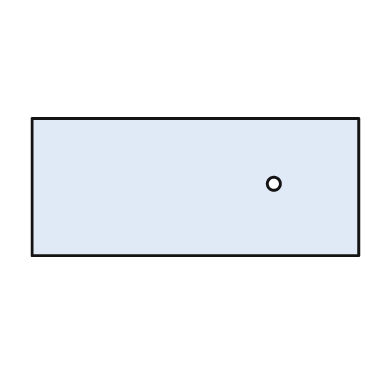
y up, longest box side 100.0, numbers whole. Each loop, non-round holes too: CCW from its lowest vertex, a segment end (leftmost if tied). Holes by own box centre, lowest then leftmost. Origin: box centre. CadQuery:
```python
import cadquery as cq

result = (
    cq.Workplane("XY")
    .moveTo(-50.0, -21.0)
    .lineTo(50.0, -21.0)
    .lineTo(50.0, 21.0)
    .lineTo(-50.0, 21.0)
    .close()
    .moveTo(24.0, 1.0)
    .circle(2.0)
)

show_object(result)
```